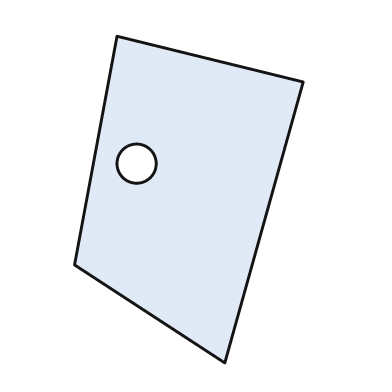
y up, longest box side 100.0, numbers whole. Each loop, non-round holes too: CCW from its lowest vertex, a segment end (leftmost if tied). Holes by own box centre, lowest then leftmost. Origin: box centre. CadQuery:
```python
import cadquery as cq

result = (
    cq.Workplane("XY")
    .moveTo(11.0, -50.0)
    .lineTo(35.0, 36.0)
    .lineTo(-22.0, 50.0)
    .lineTo(-35.0, -20.0)
    .close()
    .moveTo(-16.0, 11.0)
    .circle(6.0)
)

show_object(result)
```